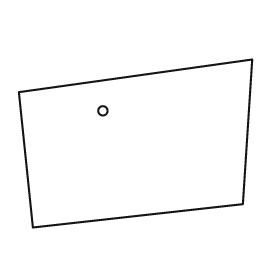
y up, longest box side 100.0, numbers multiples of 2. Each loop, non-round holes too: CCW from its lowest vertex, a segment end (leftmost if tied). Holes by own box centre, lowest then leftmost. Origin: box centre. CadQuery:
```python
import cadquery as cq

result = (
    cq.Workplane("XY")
    .moveTo(-44.0, -36.0)
    .lineTo(46.0, -26.0)
    .lineTo(50.0, 36.0)
    .lineTo(-50.0, 22.0)
    .close()
    .moveTo(-14.0, 14.0)
    .circle(2.0)
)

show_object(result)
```